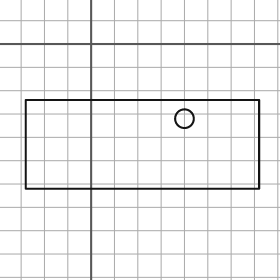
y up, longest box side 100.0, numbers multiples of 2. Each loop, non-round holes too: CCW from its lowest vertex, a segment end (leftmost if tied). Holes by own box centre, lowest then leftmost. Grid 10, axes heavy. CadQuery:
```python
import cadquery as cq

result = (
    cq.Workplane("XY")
    .moveTo(-28.0, -62.0)
    .lineTo(72.0, -62.0)
    .lineTo(72.0, -24.0)
    .lineTo(-28.0, -24.0)
    .close()
    .moveTo(40.0, -32.0)
    .circle(4.0)
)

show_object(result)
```